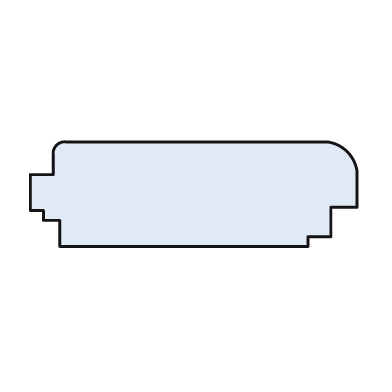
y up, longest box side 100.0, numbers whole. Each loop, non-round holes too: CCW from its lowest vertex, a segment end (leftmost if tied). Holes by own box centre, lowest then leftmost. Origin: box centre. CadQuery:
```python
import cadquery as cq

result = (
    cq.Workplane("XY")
    .moveTo(-41.0, -16.0)
    .lineTo(35.0, -16.0)
    .lineTo(35.0, -13.0)
    .lineTo(42.0, -13.0)
    .lineTo(42.0, -4.0)
    .lineTo(50.0, -4.0)
    .lineTo(50.0, 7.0)
    .threePointArc((47.0, 13.0), (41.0, 16.0))
    .lineTo(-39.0, 16.0)
    .threePointArc((-42.0, 15.0), (-43.0, 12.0))
    .lineTo(-43.0, 6.0)
    .lineTo(-50.0, 6.0)
    .lineTo(-50.0, -5.0)
    .lineTo(-46.0, -5.0)
    .lineTo(-46.0, -8.0)
    .lineTo(-41.0, -8.0)
    .close()
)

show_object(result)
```